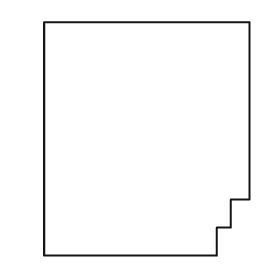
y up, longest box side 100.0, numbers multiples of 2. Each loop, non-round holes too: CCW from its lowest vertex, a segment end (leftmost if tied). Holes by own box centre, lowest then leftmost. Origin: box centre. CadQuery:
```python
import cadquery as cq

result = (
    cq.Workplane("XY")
    .moveTo(-44.0, -50.0)
    .lineTo(30.0, -50.0)
    .lineTo(30.0, -38.0)
    .lineTo(36.0, -38.0)
    .lineTo(36.0, -26.0)
    .lineTo(44.0, -26.0)
    .lineTo(44.0, 50.0)
    .lineTo(-44.0, 50.0)
    .close()
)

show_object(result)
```